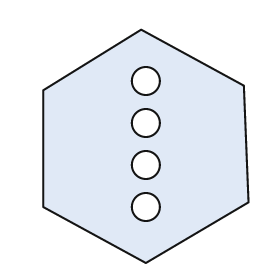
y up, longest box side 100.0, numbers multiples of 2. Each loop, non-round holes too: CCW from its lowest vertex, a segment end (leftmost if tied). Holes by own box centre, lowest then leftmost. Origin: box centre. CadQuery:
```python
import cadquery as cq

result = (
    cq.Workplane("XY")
    .moveTo(0.0, -50.0)
    .lineTo(44.0, -24.0)
    .lineTo(42.0, 26.0)
    .lineTo(-2.0, 50.0)
    .lineTo(-44.0, 24.0)
    .lineTo(-44.0, -26.0)
    .close()
    .moveTo(0.0, -26.0)
    .circle(6.0)
    .moveTo(0.0, -8.0)
    .circle(6.0)
    .moveTo(0.0, 10.0)
    .circle(6.0)
    .moveTo(0.0, 28.0)
    .circle(6.0)
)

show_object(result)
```